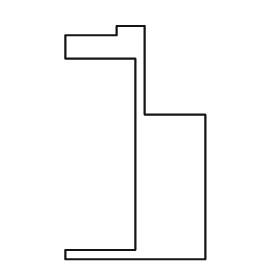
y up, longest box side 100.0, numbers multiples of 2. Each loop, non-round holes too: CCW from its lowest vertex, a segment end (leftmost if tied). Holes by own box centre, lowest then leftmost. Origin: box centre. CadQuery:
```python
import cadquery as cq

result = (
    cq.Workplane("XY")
    .moveTo(-30.0, -50.0)
    .lineTo(30.0, -50.0)
    .lineTo(30.0, 12.0)
    .lineTo(4.0, 12.0)
    .lineTo(4.0, 50.0)
    .lineTo(-8.0, 50.0)
    .lineTo(-8.0, 46.0)
    .lineTo(-30.0, 46.0)
    .lineTo(-30.0, 36.0)
    .lineTo(0.0, 36.0)
    .lineTo(0.0, -46.0)
    .lineTo(-30.0, -46.0)
    .close()
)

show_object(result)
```